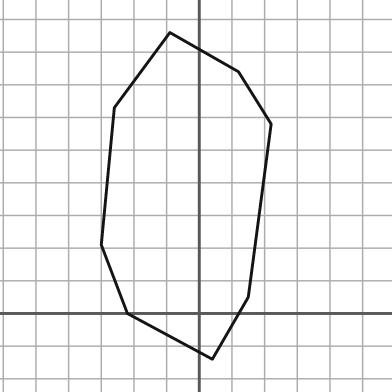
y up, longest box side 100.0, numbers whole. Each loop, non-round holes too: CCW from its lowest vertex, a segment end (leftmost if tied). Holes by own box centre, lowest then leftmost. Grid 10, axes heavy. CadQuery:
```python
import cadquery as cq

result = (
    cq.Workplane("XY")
    .moveTo(4.0, -14.0)
    .lineTo(15.0, 5.0)
    .lineTo(22.0, 58.0)
    .lineTo(12.0, 74.0)
    .lineTo(-9.0, 86.0)
    .lineTo(-26.0, 63.0)
    .lineTo(-30.0, 21.0)
    .lineTo(-22.0, 0.0)
    .close()
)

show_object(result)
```